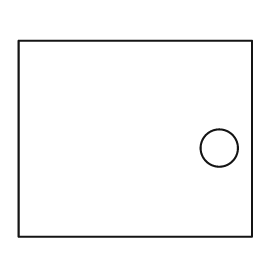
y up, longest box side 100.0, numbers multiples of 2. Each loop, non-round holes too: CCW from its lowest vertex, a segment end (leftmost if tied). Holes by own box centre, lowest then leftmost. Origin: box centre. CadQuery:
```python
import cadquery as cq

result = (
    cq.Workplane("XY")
    .moveTo(-50.0, -42.0)
    .lineTo(50.0, -42.0)
    .lineTo(50.0, 42.0)
    .lineTo(-50.0, 42.0)
    .close()
    .moveTo(36.0, -4.0)
    .circle(8.0)
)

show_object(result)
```